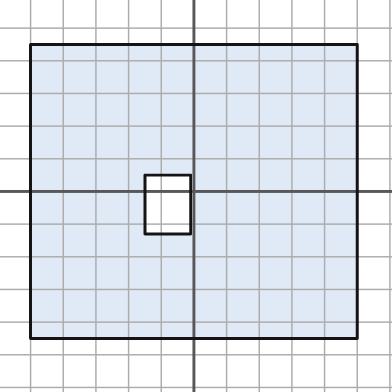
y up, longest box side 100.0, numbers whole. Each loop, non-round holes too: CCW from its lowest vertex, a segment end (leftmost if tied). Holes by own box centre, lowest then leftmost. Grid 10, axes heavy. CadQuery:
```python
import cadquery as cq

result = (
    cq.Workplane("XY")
    .moveTo(-50.0, -45.0)
    .lineTo(50.0, -45.0)
    .lineTo(50.0, 45.0)
    .lineTo(-50.0, 45.0)
    .close()
    .moveTo(-15.0, -13.0)
    .lineTo(-1.0, -13.0)
    .lineTo(-1.0, 5.0)
    .lineTo(-15.0, 5.0)
    .close()
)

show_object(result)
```